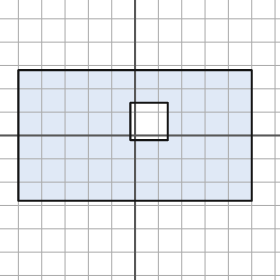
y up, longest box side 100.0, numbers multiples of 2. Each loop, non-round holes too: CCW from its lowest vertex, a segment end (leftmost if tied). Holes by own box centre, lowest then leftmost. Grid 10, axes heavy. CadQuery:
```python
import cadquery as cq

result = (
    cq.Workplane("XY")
    .moveTo(-50.0, -28.0)
    .lineTo(50.0, -28.0)
    .lineTo(50.0, 28.0)
    .lineTo(-50.0, 28.0)
    .close()
    .moveTo(-2.0, -2.0)
    .lineTo(14.0, -2.0)
    .lineTo(14.0, 14.0)
    .lineTo(-2.0, 14.0)
    .close()
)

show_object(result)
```